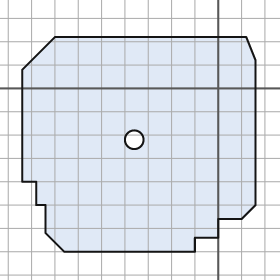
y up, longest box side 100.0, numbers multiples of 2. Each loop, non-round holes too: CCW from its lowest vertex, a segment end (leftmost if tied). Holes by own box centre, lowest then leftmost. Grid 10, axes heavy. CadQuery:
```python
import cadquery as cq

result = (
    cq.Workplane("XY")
    .moveTo(-66.0, -70.0)
    .lineTo(-10.0, -70.0)
    .lineTo(-10.0, -64.0)
    .lineTo(0.0, -64.0)
    .lineTo(0.0, -56.0)
    .lineTo(10.0, -56.0)
    .lineTo(16.0, -50.0)
    .lineTo(16.0, 12.0)
    .lineTo(12.0, 22.0)
    .lineTo(-70.0, 22.0)
    .lineTo(-84.0, 8.0)
    .lineTo(-84.0, -40.0)
    .lineTo(-78.0, -40.0)
    .lineTo(-78.0, -50.0)
    .lineTo(-74.0, -50.0)
    .lineTo(-74.0, -62.0)
    .close()
    .moveTo(-36.0, -22.0)
    .circle(4.0)
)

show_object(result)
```